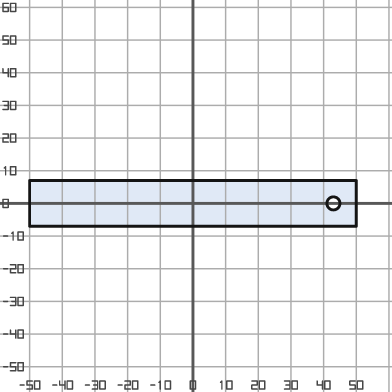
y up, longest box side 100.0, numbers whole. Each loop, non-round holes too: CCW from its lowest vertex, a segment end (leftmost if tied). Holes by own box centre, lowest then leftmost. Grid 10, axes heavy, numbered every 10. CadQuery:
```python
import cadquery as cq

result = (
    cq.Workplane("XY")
    .moveTo(-50.0, -7.0)
    .lineTo(50.0, -7.0)
    .lineTo(50.0, 7.0)
    .lineTo(-50.0, 7.0)
    .close()
    .moveTo(43.0, 0.0)
    .circle(2.0)
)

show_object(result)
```